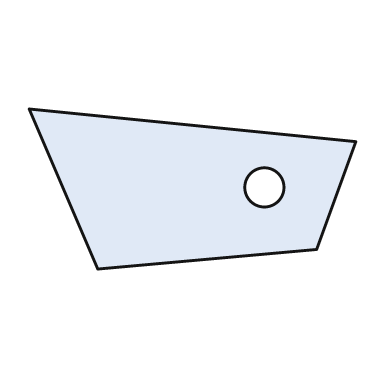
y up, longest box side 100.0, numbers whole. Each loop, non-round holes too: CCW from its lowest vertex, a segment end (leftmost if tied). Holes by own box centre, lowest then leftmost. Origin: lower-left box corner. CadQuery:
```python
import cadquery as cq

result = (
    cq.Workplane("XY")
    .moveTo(21.0, 0.0)
    .lineTo(88.0, 6.0)
    .lineTo(100.0, 39.0)
    .lineTo(0.0, 49.0)
    .close()
    .moveTo(72.0, 25.0)
    .circle(6.0)
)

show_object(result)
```